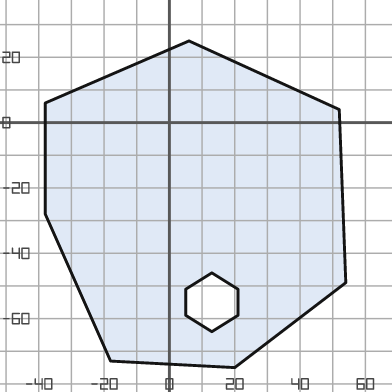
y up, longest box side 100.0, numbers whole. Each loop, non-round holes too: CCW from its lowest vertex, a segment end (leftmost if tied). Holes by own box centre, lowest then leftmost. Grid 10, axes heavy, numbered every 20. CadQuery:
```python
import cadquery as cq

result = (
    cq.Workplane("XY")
    .moveTo(20.0, -75.0)
    .lineTo(54.0, -49.0)
    .lineTo(52.0, 4.0)
    .lineTo(6.0, 25.0)
    .lineTo(-38.0, 6.0)
    .lineTo(-38.0, -28.0)
    .lineTo(-18.0, -73.0)
    .close()
    .moveTo(13.0, -64.0)
    .lineTo(21.0, -59.0)
    .lineTo(21.0, -51.0)
    .lineTo(13.0, -46.0)
    .lineTo(5.0, -51.0)
    .lineTo(5.0, -59.0)
    .close()
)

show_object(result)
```